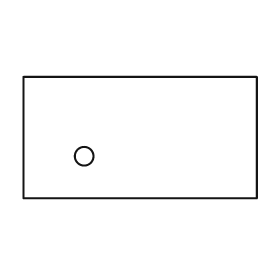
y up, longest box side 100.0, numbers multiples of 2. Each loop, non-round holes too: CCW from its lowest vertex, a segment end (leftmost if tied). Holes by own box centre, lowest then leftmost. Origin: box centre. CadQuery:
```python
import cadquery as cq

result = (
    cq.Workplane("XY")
    .moveTo(-50.0, -26.0)
    .lineTo(50.0, -26.0)
    .lineTo(50.0, 26.0)
    .lineTo(-50.0, 26.0)
    .close()
    .moveTo(-24.0, -8.0)
    .circle(4.0)
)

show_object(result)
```